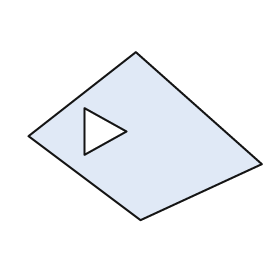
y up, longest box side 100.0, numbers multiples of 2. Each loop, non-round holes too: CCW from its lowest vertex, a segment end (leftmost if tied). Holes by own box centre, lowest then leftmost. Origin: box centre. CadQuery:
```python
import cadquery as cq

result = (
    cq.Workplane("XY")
    .moveTo(-2.0, -36.0)
    .lineTo(50.0, -12.0)
    .lineTo(-4.0, 36.0)
    .lineTo(-50.0, 0.0)
    .close()
    .moveTo(-26.0, -8.0)
    .lineTo(-8.0, 2.0)
    .lineTo(-26.0, 12.0)
    .close()
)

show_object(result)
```